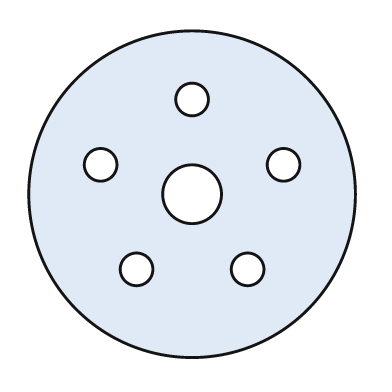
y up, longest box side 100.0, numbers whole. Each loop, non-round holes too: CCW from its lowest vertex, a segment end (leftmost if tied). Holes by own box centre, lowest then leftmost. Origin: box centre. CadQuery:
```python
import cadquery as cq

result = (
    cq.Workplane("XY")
    .moveTo(0.0, 0.0)
    .circle(50.0)
    .moveTo(-17.0, -23.0)
    .circle(5.0)
    .moveTo(17.0, -23.0)
    .circle(5.0)
    .moveTo(0.0, 0.0)
    .circle(9.0)
    .moveTo(-28.0, 9.0)
    .circle(5.0)
    .moveTo(28.0, 9.0)
    .circle(5.0)
    .moveTo(0.0, 29.0)
    .circle(5.0)
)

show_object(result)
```